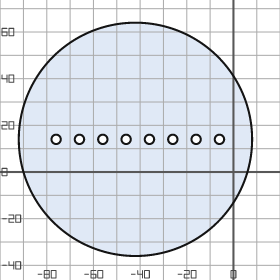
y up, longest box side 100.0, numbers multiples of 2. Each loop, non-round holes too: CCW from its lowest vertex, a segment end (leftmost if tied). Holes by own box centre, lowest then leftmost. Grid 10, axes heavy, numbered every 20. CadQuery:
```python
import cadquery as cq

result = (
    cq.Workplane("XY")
    .moveTo(-42.0, 14.0)
    .circle(50.0)
    .moveTo(-76.0, 14.0)
    .circle(2.0)
    .moveTo(-66.0, 14.0)
    .circle(2.0)
    .moveTo(-56.0, 14.0)
    .circle(2.0)
    .moveTo(-46.0, 14.0)
    .circle(2.0)
    .moveTo(-36.0, 14.0)
    .circle(2.0)
    .moveTo(-26.0, 14.0)
    .circle(2.0)
    .moveTo(-16.0, 14.0)
    .circle(2.0)
    .moveTo(-6.0, 14.0)
    .circle(2.0)
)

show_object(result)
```